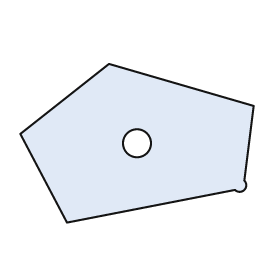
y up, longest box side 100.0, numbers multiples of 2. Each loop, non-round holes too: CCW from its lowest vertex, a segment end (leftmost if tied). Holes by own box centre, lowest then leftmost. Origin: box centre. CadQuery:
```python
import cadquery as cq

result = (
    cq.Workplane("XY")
    .moveTo(-30.0, -34.0)
    .lineTo(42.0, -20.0)
    .threePointArc((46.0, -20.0), (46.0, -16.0))
    .lineTo(50.0, 16.0)
    .lineTo(-12.0, 34.0)
    .lineTo(-50.0, 4.0)
    .close()
    .moveTo(0.0, 0.0)
    .circle(6.0)
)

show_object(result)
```